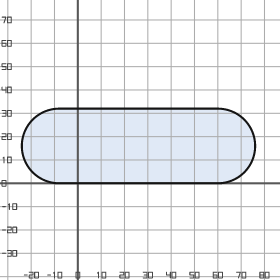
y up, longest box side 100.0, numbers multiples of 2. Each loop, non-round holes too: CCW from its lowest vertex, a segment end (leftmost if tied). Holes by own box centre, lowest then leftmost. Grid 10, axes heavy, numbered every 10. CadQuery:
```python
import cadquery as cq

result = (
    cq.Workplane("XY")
    .moveTo(-8.0, 0.0)
    .lineTo(60.0, 0.0)
    .threePointArc((76.0, 16.0), (60.0, 32.0))
    .lineTo(-8.0, 32.0)
    .threePointArc((-24.0, 16.0), (-8.0, 0.0))
    .close()
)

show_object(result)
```